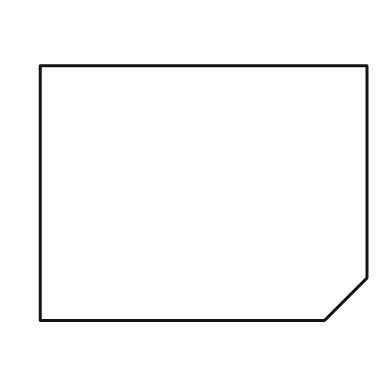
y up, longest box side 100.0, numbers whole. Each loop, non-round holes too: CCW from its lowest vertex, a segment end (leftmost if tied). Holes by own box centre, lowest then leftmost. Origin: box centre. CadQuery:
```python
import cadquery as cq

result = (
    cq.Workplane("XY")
    .moveTo(-50.0, -39.0)
    .lineTo(37.0, -39.0)
    .lineTo(50.0, -26.0)
    .lineTo(50.0, 39.0)
    .lineTo(-50.0, 39.0)
    .close()
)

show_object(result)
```